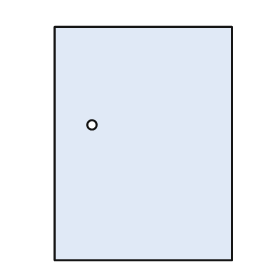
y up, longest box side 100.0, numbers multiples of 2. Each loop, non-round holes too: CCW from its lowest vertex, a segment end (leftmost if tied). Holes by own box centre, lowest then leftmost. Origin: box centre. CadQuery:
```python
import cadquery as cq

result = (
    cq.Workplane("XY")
    .moveTo(-38.0, -50.0)
    .lineTo(38.0, -50.0)
    .lineTo(38.0, 50.0)
    .lineTo(-38.0, 50.0)
    .close()
    .moveTo(-22.0, 8.0)
    .circle(2.0)
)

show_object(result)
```